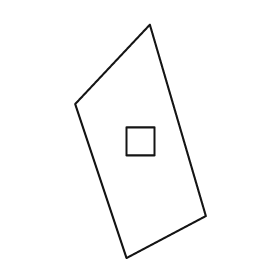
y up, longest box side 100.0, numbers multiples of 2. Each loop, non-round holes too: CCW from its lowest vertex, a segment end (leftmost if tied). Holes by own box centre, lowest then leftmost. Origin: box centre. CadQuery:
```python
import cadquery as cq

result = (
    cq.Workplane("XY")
    .moveTo(-6.0, -50.0)
    .lineTo(28.0, -32.0)
    .lineTo(4.0, 50.0)
    .lineTo(-28.0, 16.0)
    .close()
    .moveTo(-6.0, -6.0)
    .lineTo(6.0, -6.0)
    .lineTo(6.0, 6.0)
    .lineTo(-6.0, 6.0)
    .close()
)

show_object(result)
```